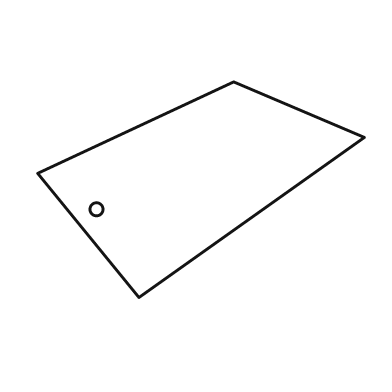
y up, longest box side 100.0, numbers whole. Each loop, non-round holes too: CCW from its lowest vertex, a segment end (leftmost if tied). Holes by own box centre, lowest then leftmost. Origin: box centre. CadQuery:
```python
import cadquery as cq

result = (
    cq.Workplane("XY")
    .moveTo(-19.0, -33.0)
    .lineTo(50.0, 16.0)
    .lineTo(10.0, 33.0)
    .lineTo(-50.0, 5.0)
    .close()
    .moveTo(-32.0, -6.0)
    .circle(2.0)
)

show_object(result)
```